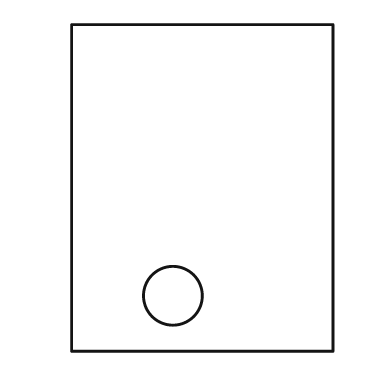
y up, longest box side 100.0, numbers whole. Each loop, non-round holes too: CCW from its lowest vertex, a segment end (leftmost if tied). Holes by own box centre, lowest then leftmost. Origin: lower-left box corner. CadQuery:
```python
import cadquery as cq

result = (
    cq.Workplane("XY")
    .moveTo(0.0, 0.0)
    .lineTo(80.0, 0.0)
    .lineTo(80.0, 100.0)
    .lineTo(0.0, 100.0)
    .close()
    .moveTo(31.0, 17.0)
    .circle(9.0)
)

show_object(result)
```